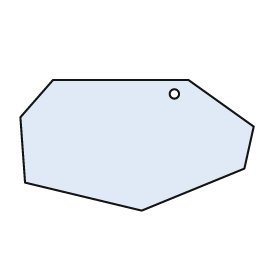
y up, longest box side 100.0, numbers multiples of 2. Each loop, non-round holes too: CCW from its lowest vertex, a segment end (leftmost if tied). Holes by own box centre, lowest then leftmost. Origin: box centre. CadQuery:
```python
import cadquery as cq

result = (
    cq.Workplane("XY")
    .moveTo(2.0, -28.0)
    .lineTo(46.0, -10.0)
    .lineTo(50.0, 8.0)
    .lineTo(22.0, 28.0)
    .lineTo(-36.0, 28.0)
    .lineTo(-50.0, 12.0)
    .lineTo(-48.0, -16.0)
    .close()
    .moveTo(16.0, 22.0)
    .circle(2.0)
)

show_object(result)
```